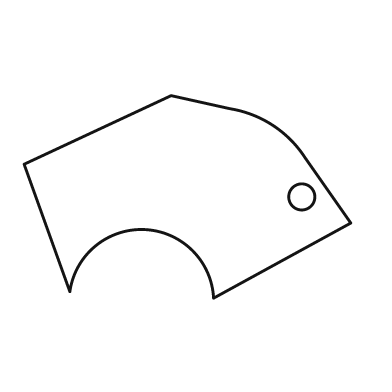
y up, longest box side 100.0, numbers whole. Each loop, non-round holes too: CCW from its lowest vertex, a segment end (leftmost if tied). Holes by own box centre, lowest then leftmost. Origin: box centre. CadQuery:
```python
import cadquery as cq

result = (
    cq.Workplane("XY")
    .moveTo(8.0, -31.0)
    .lineTo(50.0, -8.0)
    .lineTo(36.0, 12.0)
    .threePointArc((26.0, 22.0), (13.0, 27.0))
    .lineTo(-5.0, 31.0)
    .lineTo(-50.0, 10.0)
    .lineTo(-36.0, -29.0)
    .threePointArc((-13.0, -10.0), (8.0, -31.0))
    .close()
    .moveTo(35.0, 0.0)
    .circle(4.0)
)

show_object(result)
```